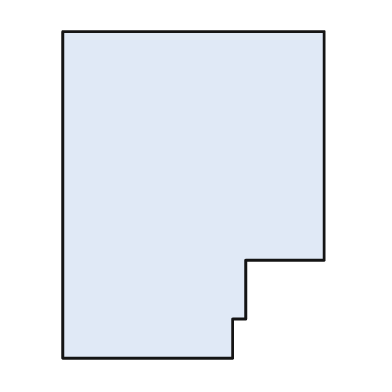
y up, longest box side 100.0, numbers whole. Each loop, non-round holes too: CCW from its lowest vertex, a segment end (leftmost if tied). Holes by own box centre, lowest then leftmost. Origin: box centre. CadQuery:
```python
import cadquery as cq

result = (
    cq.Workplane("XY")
    .moveTo(-40.0, -50.0)
    .lineTo(12.0, -50.0)
    .lineTo(12.0, -38.0)
    .lineTo(16.0, -38.0)
    .lineTo(16.0, -20.0)
    .lineTo(40.0, -20.0)
    .lineTo(40.0, 50.0)
    .lineTo(-40.0, 50.0)
    .close()
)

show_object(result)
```